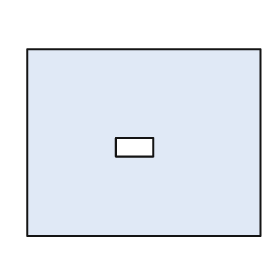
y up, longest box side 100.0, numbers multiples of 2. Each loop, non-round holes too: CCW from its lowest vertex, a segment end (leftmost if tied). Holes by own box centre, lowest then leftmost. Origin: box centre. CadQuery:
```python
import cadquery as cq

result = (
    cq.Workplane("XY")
    .moveTo(-50.0, -40.0)
    .lineTo(50.0, -40.0)
    .lineTo(50.0, 40.0)
    .lineTo(-50.0, 40.0)
    .close()
    .moveTo(-12.0, -6.0)
    .lineTo(4.0, -6.0)
    .lineTo(4.0, 2.0)
    .lineTo(-12.0, 2.0)
    .close()
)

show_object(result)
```